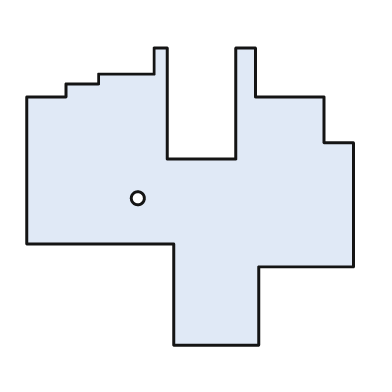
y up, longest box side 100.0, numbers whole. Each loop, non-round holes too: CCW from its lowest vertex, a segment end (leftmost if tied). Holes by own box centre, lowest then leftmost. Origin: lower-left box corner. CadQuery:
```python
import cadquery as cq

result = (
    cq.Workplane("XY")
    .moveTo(45.0, 0.0)
    .lineTo(71.0, 0.0)
    .lineTo(71.0, 24.0)
    .lineTo(100.0, 24.0)
    .lineTo(100.0, 62.0)
    .lineTo(91.0, 62.0)
    .lineTo(91.0, 76.0)
    .lineTo(70.0, 76.0)
    .lineTo(70.0, 91.0)
    .lineTo(64.0, 91.0)
    .lineTo(64.0, 57.0)
    .lineTo(43.0, 57.0)
    .lineTo(43.0, 91.0)
    .lineTo(39.0, 91.0)
    .lineTo(39.0, 83.0)
    .lineTo(22.0, 83.0)
    .lineTo(22.0, 80.0)
    .lineTo(12.0, 80.0)
    .lineTo(12.0, 76.0)
    .lineTo(0.0, 76.0)
    .lineTo(0.0, 31.0)
    .lineTo(45.0, 31.0)
    .close()
    .moveTo(34.0, 45.0)
    .circle(2.0)
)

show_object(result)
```